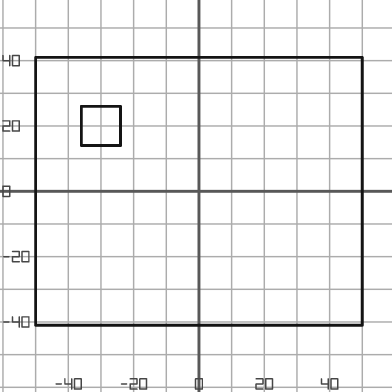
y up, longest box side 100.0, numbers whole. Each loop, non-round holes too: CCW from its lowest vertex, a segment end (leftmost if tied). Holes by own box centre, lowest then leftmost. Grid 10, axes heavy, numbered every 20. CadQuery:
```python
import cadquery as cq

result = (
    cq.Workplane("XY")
    .moveTo(-50.0, -41.0)
    .lineTo(50.0, -41.0)
    .lineTo(50.0, 41.0)
    .lineTo(-50.0, 41.0)
    .close()
    .moveTo(-36.0, 14.0)
    .lineTo(-24.0, 14.0)
    .lineTo(-24.0, 26.0)
    .lineTo(-36.0, 26.0)
    .close()
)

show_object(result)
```